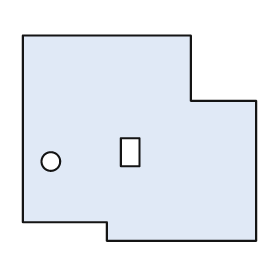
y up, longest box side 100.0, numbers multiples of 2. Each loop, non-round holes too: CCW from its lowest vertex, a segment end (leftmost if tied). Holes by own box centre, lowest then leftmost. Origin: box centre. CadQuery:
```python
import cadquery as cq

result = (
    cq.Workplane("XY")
    .moveTo(-14.0, -44.0)
    .lineTo(50.0, -44.0)
    .lineTo(50.0, 16.0)
    .lineTo(22.0, 16.0)
    .lineTo(22.0, 44.0)
    .lineTo(-50.0, 44.0)
    .lineTo(-50.0, -36.0)
    .lineTo(-14.0, -36.0)
    .close()
    .moveTo(-38.0, -10.0)
    .circle(4.0)
    .moveTo(-8.0, -12.0)
    .lineTo(0.0, -12.0)
    .lineTo(0.0, 0.0)
    .lineTo(-8.0, 0.0)
    .close()
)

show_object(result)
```